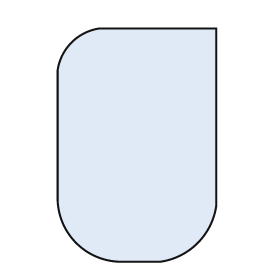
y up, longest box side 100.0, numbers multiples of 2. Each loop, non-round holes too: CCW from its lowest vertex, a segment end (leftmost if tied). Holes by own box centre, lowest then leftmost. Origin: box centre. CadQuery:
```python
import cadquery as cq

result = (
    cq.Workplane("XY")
    .moveTo(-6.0, -50.0)
    .lineTo(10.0, -50.0)
    .threePointArc((26.0, -42.0), (34.0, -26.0))
    .lineTo(34.0, 50.0)
    .lineTo(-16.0, 50.0)
    .threePointArc((-28.0, 44.0), (-34.0, 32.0))
    .lineTo(-34.0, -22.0)
    .threePointArc((-26.0, -42.0), (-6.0, -50.0))
    .close()
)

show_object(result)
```